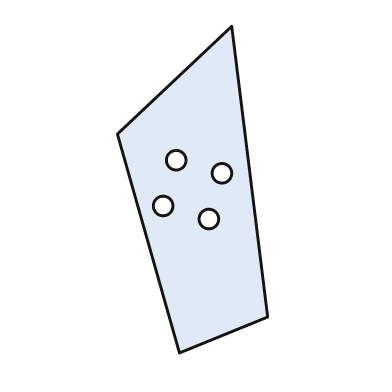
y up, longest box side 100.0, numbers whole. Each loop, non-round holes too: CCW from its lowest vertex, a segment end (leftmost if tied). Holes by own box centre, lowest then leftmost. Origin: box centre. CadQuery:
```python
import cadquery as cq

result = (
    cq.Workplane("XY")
    .moveTo(-4.0, -50.0)
    .lineTo(23.0, -39.0)
    .lineTo(12.0, 50.0)
    .lineTo(-23.0, 17.0)
    .close()
    .moveTo(5.0, -9.0)
    .circle(3.0)
    .moveTo(-9.0, -5.0)
    .circle(3.0)
    .moveTo(9.0, 5.0)
    .circle(3.0)
    .moveTo(-5.0, 9.0)
    .circle(3.0)
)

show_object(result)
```